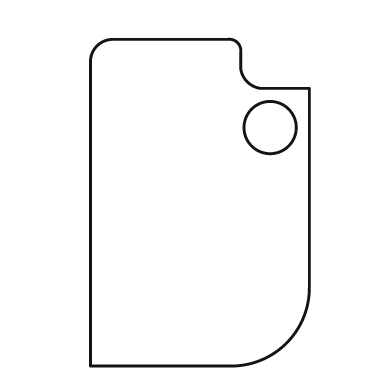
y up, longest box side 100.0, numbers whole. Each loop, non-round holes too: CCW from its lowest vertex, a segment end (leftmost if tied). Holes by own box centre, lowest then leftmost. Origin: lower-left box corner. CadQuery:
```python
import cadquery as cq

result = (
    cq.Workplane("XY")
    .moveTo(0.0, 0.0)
    .lineTo(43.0, 0.0)
    .threePointArc((60.0, 7.0), (67.0, 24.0))
    .lineTo(67.0, 85.0)
    .lineTo(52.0, 85.0)
    .threePointArc((48.0, 87.0), (46.0, 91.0))
    .lineTo(46.0, 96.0)
    .threePointArc((45.0, 99.0), (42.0, 100.0))
    .lineTo(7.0, 100.0)
    .threePointArc((2.0, 98.0), (0.0, 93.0))
    .close()
    .moveTo(55.0, 73.0)
    .circle(8.0)
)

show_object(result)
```